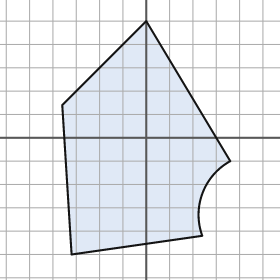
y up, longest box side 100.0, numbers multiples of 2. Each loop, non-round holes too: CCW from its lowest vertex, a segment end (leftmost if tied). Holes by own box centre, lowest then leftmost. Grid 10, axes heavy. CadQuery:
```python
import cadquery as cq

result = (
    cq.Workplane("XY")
    .moveTo(-32.0, -50.0)
    .lineTo(24.0, -42.0)
    .threePointArc((24.0, -24.0), (36.0, -10.0))
    .lineTo(0.0, 50.0)
    .lineTo(-36.0, 14.0)
    .close()
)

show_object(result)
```